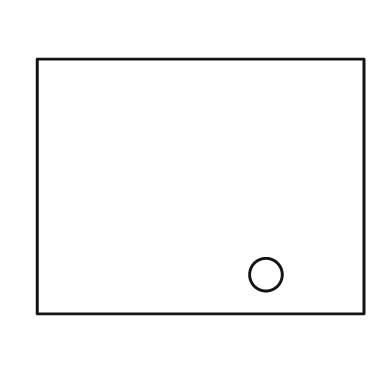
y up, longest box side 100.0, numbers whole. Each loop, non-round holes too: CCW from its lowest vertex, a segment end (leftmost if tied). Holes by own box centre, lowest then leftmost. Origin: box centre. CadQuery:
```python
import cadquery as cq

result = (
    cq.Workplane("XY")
    .moveTo(-50.0, -39.0)
    .lineTo(50.0, -39.0)
    .lineTo(50.0, 39.0)
    .lineTo(-50.0, 39.0)
    .close()
    .moveTo(20.0, -27.0)
    .circle(5.0)
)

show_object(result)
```